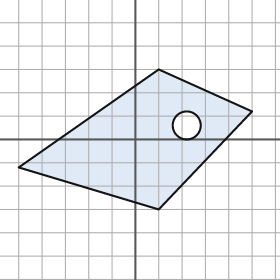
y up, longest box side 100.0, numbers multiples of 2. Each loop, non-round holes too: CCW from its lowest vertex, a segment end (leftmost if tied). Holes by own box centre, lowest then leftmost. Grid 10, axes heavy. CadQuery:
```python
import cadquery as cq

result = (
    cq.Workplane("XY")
    .moveTo(10.0, -30.0)
    .lineTo(50.0, 12.0)
    .lineTo(10.0, 30.0)
    .lineTo(-50.0, -12.0)
    .close()
    .moveTo(22.0, 6.0)
    .circle(6.0)
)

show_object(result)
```